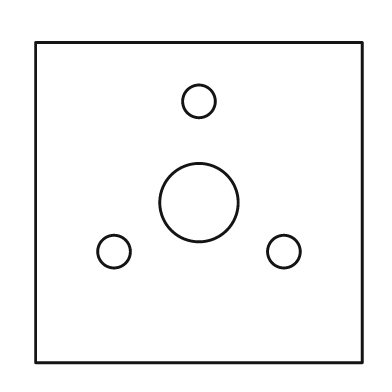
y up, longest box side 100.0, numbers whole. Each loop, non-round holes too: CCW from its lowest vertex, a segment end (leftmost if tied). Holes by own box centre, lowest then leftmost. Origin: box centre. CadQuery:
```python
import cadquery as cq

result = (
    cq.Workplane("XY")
    .moveTo(-50.0, -49.0)
    .lineTo(50.0, -49.0)
    .lineTo(50.0, 49.0)
    .lineTo(-50.0, 49.0)
    .close()
    .moveTo(-26.0, -15.0)
    .circle(5.0)
    .moveTo(26.0, -15.0)
    .circle(5.0)
    .moveTo(0.0, 0.0)
    .circle(12.0)
    .moveTo(0.0, 31.0)
    .circle(5.0)
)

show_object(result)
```